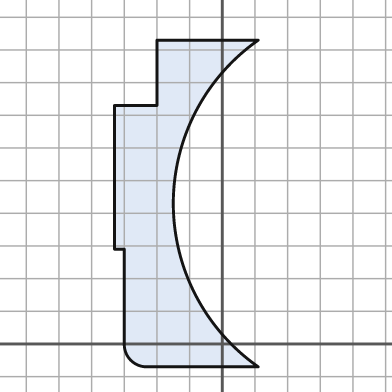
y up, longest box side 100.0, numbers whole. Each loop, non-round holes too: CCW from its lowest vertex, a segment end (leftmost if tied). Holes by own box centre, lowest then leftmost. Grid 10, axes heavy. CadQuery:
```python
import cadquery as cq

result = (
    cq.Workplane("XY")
    .moveTo(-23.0, -7.0)
    .lineTo(11.0, -7.0)
    .threePointArc((-15.0, 43.0), (11.0, 93.0))
    .lineTo(-20.0, 93.0)
    .lineTo(-20.0, 73.0)
    .lineTo(-33.0, 73.0)
    .lineTo(-33.0, 29.0)
    .lineTo(-30.0, 29.0)
    .lineTo(-30.0, 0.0)
    .threePointArc((-28.0, -5.0), (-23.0, -7.0))
    .close()
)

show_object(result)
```